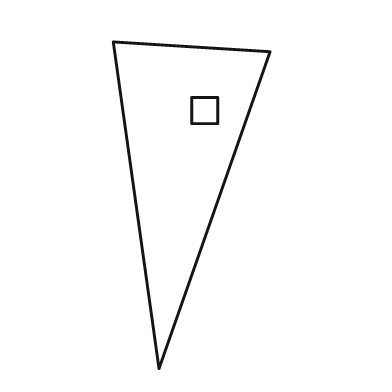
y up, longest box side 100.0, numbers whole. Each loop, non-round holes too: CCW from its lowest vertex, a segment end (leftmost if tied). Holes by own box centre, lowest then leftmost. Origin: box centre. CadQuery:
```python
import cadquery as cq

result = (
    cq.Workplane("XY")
    .moveTo(-10.0, -50.0)
    .lineTo(24.0, 47.0)
    .lineTo(-24.0, 50.0)
    .close()
    .moveTo(0.0, 25.0)
    .lineTo(8.0, 25.0)
    .lineTo(8.0, 33.0)
    .lineTo(0.0, 33.0)
    .close()
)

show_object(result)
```